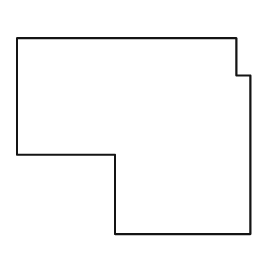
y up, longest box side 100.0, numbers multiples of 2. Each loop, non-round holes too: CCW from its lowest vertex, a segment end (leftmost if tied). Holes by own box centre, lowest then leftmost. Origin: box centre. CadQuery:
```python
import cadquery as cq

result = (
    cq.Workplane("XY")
    .moveTo(-8.0, -42.0)
    .lineTo(50.0, -42.0)
    .lineTo(50.0, 26.0)
    .lineTo(44.0, 26.0)
    .lineTo(44.0, 42.0)
    .lineTo(-50.0, 42.0)
    .lineTo(-50.0, -8.0)
    .lineTo(-8.0, -8.0)
    .close()
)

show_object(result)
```